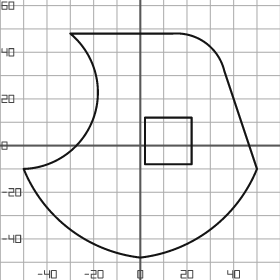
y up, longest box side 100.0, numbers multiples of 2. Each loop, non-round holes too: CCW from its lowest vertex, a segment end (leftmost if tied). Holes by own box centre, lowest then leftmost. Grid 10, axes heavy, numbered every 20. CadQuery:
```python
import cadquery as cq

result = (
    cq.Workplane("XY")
    .moveTo(0.0, -48.0)
    .threePointArc((30.0, -36.0), (50.0, -10.0))
    .lineTo(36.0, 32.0)
    .threePointArc((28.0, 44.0), (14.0, 48.0))
    .lineTo(-30.0, 48.0)
    .threePointArc((-20.0, 12.0), (-50.0, -10.0))
    .threePointArc((-30.0, -36.0), (0.0, -48.0))
    .close()
    .moveTo(2.0, -8.0)
    .lineTo(22.0, -8.0)
    .lineTo(22.0, 12.0)
    .lineTo(2.0, 12.0)
    .close()
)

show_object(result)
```